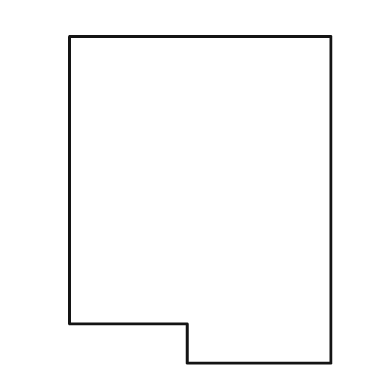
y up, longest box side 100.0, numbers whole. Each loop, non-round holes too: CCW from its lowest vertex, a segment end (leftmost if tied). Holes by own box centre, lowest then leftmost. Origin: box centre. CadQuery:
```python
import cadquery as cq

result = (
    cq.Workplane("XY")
    .moveTo(-4.0, -50.0)
    .lineTo(40.0, -50.0)
    .lineTo(40.0, 50.0)
    .lineTo(-40.0, 50.0)
    .lineTo(-40.0, -38.0)
    .lineTo(-4.0, -38.0)
    .close()
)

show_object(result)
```